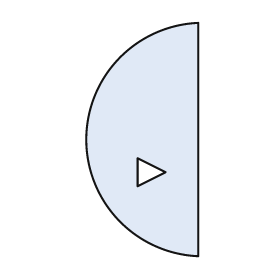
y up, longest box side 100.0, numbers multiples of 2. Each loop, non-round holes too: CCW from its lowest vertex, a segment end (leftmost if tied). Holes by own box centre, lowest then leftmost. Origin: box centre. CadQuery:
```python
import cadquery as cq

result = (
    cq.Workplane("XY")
    .moveTo(24.0, -50.0)
    .lineTo(24.0, 50.0)
    .threePointArc((-24.0, 0.0), (24.0, -50.0))
    .close()
    .moveTo(-2.0, -20.0)
    .lineTo(10.0, -14.0)
    .lineTo(-2.0, -8.0)
    .close()
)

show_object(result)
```